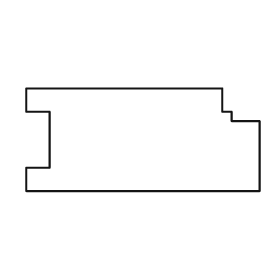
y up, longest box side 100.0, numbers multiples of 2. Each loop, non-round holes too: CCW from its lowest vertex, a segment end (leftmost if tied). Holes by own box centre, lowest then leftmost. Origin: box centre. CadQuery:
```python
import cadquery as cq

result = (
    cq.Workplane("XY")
    .moveTo(-50.0, -22.0)
    .lineTo(50.0, -22.0)
    .lineTo(50.0, 8.0)
    .lineTo(38.0, 8.0)
    .lineTo(38.0, 12.0)
    .lineTo(34.0, 12.0)
    .lineTo(34.0, 22.0)
    .lineTo(-50.0, 22.0)
    .lineTo(-50.0, 12.0)
    .lineTo(-40.0, 12.0)
    .lineTo(-40.0, -12.0)
    .lineTo(-50.0, -12.0)
    .close()
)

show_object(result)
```